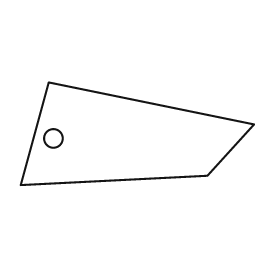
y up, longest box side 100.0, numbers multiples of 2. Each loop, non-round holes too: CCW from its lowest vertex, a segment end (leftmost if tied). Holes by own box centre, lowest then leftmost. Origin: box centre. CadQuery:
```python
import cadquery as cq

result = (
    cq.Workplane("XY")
    .moveTo(-50.0, -22.0)
    .lineTo(30.0, -18.0)
    .lineTo(50.0, 4.0)
    .lineTo(-38.0, 22.0)
    .close()
    .moveTo(-36.0, -2.0)
    .circle(4.0)
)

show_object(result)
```